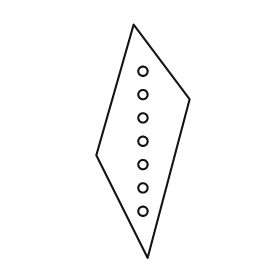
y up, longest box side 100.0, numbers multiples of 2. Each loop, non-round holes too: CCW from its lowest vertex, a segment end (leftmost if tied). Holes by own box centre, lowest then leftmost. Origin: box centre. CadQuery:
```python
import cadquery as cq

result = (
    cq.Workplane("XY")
    .moveTo(2.0, -50.0)
    .lineTo(20.0, 18.0)
    .lineTo(-4.0, 50.0)
    .lineTo(-20.0, -6.0)
    .close()
    .moveTo(0.0, -30.0)
    .circle(2.0)
    .moveTo(0.0, -20.0)
    .circle(2.0)
    .moveTo(0.0, -10.0)
    .circle(2.0)
    .moveTo(0.0, 0.0)
    .circle(2.0)
    .moveTo(0.0, 10.0)
    .circle(2.0)
    .moveTo(0.0, 20.0)
    .circle(2.0)
    .moveTo(0.0, 30.0)
    .circle(2.0)
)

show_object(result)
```